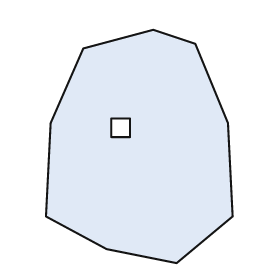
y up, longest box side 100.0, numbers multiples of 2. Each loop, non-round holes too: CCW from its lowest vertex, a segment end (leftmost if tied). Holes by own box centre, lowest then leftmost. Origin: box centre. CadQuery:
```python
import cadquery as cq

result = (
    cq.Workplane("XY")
    .moveTo(16.0, -50.0)
    .lineTo(40.0, -30.0)
    .lineTo(38.0, 10.0)
    .lineTo(24.0, 44.0)
    .lineTo(6.0, 50.0)
    .lineTo(-24.0, 42.0)
    .lineTo(-38.0, 10.0)
    .lineTo(-40.0, -30.0)
    .lineTo(-14.0, -44.0)
    .close()
    .moveTo(-12.0, 4.0)
    .lineTo(-4.0, 4.0)
    .lineTo(-4.0, 12.0)
    .lineTo(-12.0, 12.0)
    .close()
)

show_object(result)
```